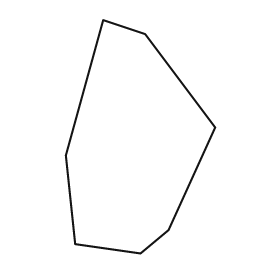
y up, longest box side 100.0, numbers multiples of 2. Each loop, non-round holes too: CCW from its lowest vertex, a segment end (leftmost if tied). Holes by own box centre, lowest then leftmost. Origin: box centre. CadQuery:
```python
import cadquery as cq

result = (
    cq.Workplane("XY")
    .moveTo(0.0, -50.0)
    .lineTo(12.0, -40.0)
    .lineTo(32.0, 4.0)
    .lineTo(2.0, 44.0)
    .lineTo(-16.0, 50.0)
    .lineTo(-32.0, -8.0)
    .lineTo(-28.0, -46.0)
    .close()
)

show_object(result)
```